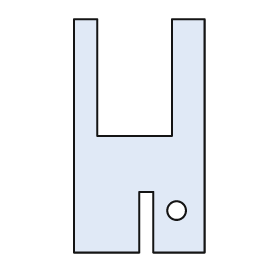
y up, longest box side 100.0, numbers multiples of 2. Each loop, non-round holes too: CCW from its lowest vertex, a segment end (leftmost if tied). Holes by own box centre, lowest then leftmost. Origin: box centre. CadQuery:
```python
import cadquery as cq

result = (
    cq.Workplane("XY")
    .moveTo(-28.0, -50.0)
    .lineTo(0.0, -50.0)
    .lineTo(0.0, -24.0)
    .lineTo(6.0, -24.0)
    .lineTo(6.0, -50.0)
    .lineTo(28.0, -50.0)
    .lineTo(28.0, 50.0)
    .lineTo(14.0, 50.0)
    .lineTo(14.0, 0.0)
    .lineTo(-18.0, 0.0)
    .lineTo(-18.0, 50.0)
    .lineTo(-28.0, 50.0)
    .close()
    .moveTo(16.0, -32.0)
    .circle(4.0)
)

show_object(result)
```